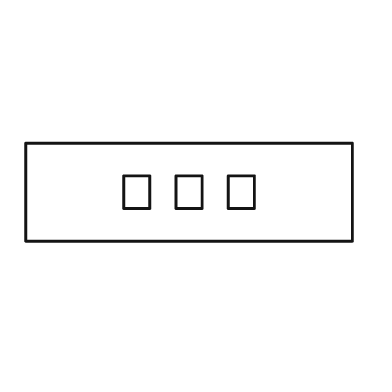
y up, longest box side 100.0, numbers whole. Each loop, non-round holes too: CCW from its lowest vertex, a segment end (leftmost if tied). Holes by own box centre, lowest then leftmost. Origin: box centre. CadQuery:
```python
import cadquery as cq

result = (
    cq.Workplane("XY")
    .moveTo(-50.0, -15.0)
    .lineTo(50.0, -15.0)
    .lineTo(50.0, 15.0)
    .lineTo(-50.0, 15.0)
    .close()
    .moveTo(-20.0, -5.0)
    .lineTo(-12.0, -5.0)
    .lineTo(-12.0, 5.0)
    .lineTo(-20.0, 5.0)
    .close()
    .moveTo(-4.0, -5.0)
    .lineTo(4.0, -5.0)
    .lineTo(4.0, 5.0)
    .lineTo(-4.0, 5.0)
    .close()
    .moveTo(12.0, -5.0)
    .lineTo(20.0, -5.0)
    .lineTo(20.0, 5.0)
    .lineTo(12.0, 5.0)
    .close()
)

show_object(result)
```